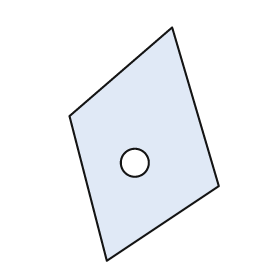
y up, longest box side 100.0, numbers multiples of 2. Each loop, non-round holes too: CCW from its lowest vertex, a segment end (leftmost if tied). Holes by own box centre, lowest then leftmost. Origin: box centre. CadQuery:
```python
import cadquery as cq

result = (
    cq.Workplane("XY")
    .moveTo(-16.0, -50.0)
    .lineTo(32.0, -18.0)
    .lineTo(12.0, 50.0)
    .lineTo(-32.0, 12.0)
    .close()
    .moveTo(-4.0, -8.0)
    .circle(6.0)
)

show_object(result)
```